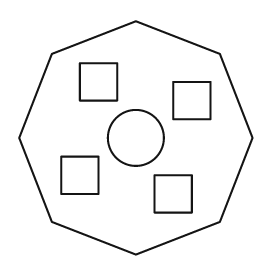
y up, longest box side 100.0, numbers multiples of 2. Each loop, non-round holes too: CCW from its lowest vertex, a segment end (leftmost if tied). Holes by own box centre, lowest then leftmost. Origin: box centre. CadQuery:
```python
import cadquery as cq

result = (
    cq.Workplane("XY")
    .moveTo(0.0, -50.0)
    .lineTo(36.0, -36.0)
    .lineTo(50.0, 0.0)
    .lineTo(36.0, 36.0)
    .lineTo(0.0, 50.0)
    .lineTo(-36.0, 36.0)
    .lineTo(-50.0, 0.0)
    .lineTo(-36.0, -36.0)
    .close()
    .moveTo(8.0, -32.0)
    .lineTo(24.0, -32.0)
    .lineTo(24.0, -16.0)
    .lineTo(8.0, -16.0)
    .close()
    .moveTo(-32.0, -24.0)
    .lineTo(-16.0, -24.0)
    .lineTo(-16.0, -8.0)
    .lineTo(-32.0, -8.0)
    .close()
    .moveTo(0.0, 0.0)
    .circle(12.0)
    .moveTo(16.0, 8.0)
    .lineTo(32.0, 8.0)
    .lineTo(32.0, 24.0)
    .lineTo(16.0, 24.0)
    .close()
    .moveTo(-24.0, 16.0)
    .lineTo(-8.0, 16.0)
    .lineTo(-8.0, 32.0)
    .lineTo(-24.0, 32.0)
    .close()
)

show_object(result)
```